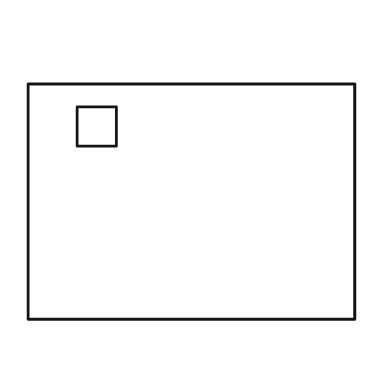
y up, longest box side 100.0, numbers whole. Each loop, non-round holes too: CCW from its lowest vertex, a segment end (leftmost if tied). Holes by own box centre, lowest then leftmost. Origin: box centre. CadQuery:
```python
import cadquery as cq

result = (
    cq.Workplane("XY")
    .moveTo(-50.0, -36.0)
    .lineTo(50.0, -36.0)
    .lineTo(50.0, 36.0)
    .lineTo(-50.0, 36.0)
    .close()
    .moveTo(-35.0, 17.0)
    .lineTo(-23.0, 17.0)
    .lineTo(-23.0, 29.0)
    .lineTo(-35.0, 29.0)
    .close()
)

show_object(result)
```